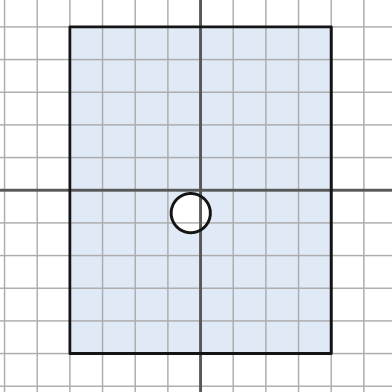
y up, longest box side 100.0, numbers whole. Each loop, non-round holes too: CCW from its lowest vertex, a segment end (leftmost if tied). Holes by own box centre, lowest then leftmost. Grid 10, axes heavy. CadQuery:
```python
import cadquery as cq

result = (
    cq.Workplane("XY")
    .moveTo(-40.0, -50.0)
    .lineTo(40.0, -50.0)
    .lineTo(40.0, 50.0)
    .lineTo(-40.0, 50.0)
    .close()
    .moveTo(-3.0, -7.0)
    .circle(6.0)
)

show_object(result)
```